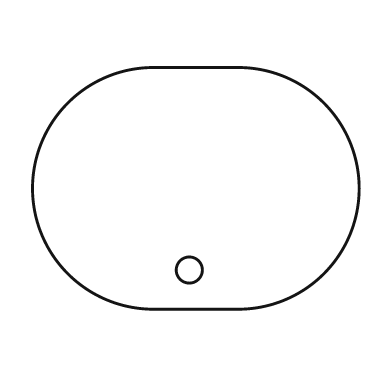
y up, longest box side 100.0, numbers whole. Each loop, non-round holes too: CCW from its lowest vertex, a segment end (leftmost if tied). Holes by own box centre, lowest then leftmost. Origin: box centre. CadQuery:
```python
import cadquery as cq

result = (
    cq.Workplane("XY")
    .moveTo(-13.0, -37.0)
    .lineTo(13.0, -37.0)
    .threePointArc((50.0, 0.0), (13.0, 37.0))
    .lineTo(-13.0, 37.0)
    .threePointArc((-50.0, 0.0), (-13.0, -37.0))
    .close()
    .moveTo(-2.0, -25.0)
    .circle(4.0)
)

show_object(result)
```